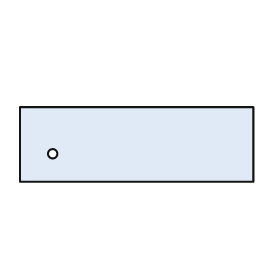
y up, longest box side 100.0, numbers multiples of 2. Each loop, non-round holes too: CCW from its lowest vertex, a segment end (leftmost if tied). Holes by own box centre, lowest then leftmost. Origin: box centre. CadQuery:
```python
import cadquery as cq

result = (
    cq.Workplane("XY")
    .moveTo(-50.0, -16.0)
    .lineTo(50.0, -16.0)
    .lineTo(50.0, 16.0)
    .lineTo(-50.0, 16.0)
    .close()
    .moveTo(-36.0, -4.0)
    .circle(2.0)
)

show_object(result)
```